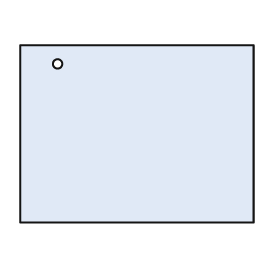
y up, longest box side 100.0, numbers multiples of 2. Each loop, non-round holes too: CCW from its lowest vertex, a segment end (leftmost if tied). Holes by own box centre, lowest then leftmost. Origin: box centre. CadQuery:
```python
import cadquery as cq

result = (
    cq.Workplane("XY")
    .moveTo(-50.0, -38.0)
    .lineTo(50.0, -38.0)
    .lineTo(50.0, 38.0)
    .lineTo(-50.0, 38.0)
    .close()
    .moveTo(-34.0, 30.0)
    .circle(2.0)
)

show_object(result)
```